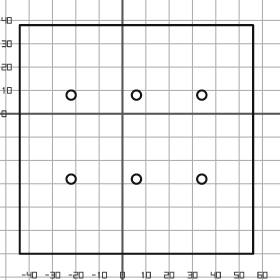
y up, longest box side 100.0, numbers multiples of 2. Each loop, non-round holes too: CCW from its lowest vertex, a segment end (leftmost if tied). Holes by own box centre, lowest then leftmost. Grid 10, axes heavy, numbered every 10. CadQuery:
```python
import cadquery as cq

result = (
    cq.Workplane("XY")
    .moveTo(-44.0, -60.0)
    .lineTo(56.0, -60.0)
    .lineTo(56.0, 38.0)
    .lineTo(-44.0, 38.0)
    .close()
    .moveTo(-22.0, -28.0)
    .circle(2.0)
    .moveTo(6.0, -28.0)
    .circle(2.0)
    .moveTo(34.0, -28.0)
    .circle(2.0)
    .moveTo(-22.0, 8.0)
    .circle(2.0)
    .moveTo(6.0, 8.0)
    .circle(2.0)
    .moveTo(34.0, 8.0)
    .circle(2.0)
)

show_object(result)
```